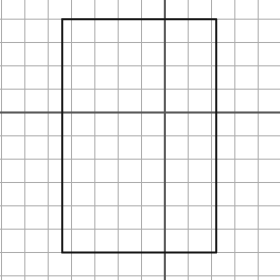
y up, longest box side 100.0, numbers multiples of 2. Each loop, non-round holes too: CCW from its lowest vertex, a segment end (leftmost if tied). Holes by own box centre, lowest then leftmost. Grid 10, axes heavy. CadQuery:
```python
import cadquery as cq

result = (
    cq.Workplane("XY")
    .moveTo(-44.0, -60.0)
    .lineTo(22.0, -60.0)
    .lineTo(22.0, 40.0)
    .lineTo(-44.0, 40.0)
    .close()
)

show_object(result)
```